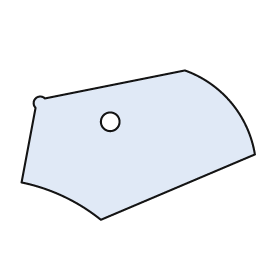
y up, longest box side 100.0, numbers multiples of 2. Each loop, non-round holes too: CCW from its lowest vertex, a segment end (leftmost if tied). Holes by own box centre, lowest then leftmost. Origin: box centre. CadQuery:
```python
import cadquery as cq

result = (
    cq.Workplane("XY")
    .moveTo(-16.0, -32.0)
    .lineTo(50.0, -4.0)
    .threePointArc((40.0, 18.0), (20.0, 32.0))
    .lineTo(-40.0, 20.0)
    .threePointArc((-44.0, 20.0), (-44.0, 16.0))
    .lineTo(-50.0, -16.0)
    .threePointArc((-32.0, -22.0), (-16.0, -32.0))
    .close()
    .moveTo(-12.0, 10.0)
    .circle(4.0)
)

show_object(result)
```